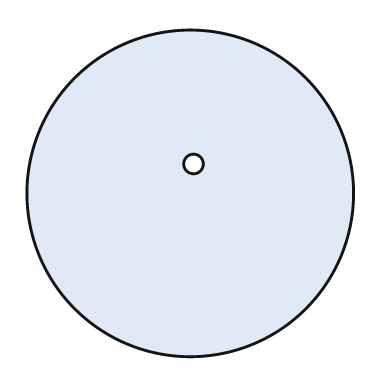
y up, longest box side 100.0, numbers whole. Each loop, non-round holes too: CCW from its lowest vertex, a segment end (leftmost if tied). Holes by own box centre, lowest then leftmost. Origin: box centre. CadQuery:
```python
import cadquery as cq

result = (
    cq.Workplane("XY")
    .moveTo(0.0, 0.0)
    .circle(50.0)
    .moveTo(1.0, 9.0)
    .circle(3.0)
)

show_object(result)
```